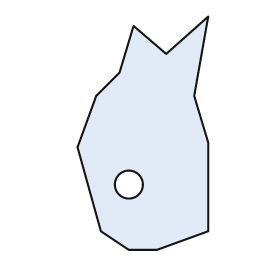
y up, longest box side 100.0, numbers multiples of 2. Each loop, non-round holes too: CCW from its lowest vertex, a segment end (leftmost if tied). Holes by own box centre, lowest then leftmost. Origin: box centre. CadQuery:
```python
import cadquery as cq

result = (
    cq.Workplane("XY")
    .moveTo(-6.0, -50.0)
    .lineTo(6.0, -50.0)
    .lineTo(28.0, -42.0)
    .lineTo(28.0, -4.0)
    .lineTo(22.0, 16.0)
    .lineTo(28.0, 50.0)
    .lineTo(10.0, 34.0)
    .lineTo(-4.0, 46.0)
    .lineTo(-10.0, 26.0)
    .lineTo(-20.0, 16.0)
    .lineTo(-28.0, -6.0)
    .lineTo(-18.0, -42.0)
    .close()
    .moveTo(-6.0, -22.0)
    .circle(6.0)
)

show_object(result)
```